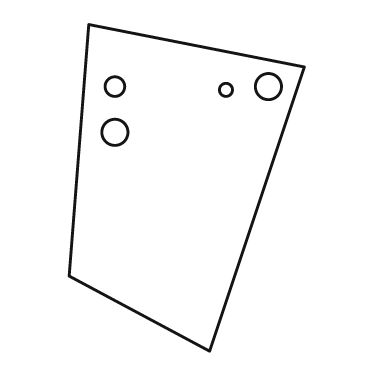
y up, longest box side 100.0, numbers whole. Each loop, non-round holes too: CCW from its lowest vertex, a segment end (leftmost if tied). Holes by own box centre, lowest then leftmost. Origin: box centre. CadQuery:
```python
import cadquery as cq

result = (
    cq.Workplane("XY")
    .moveTo(7.0, -50.0)
    .lineTo(36.0, 37.0)
    .lineTo(-30.0, 50.0)
    .lineTo(-36.0, -27.0)
    .close()
    .moveTo(-22.0, 17.0)
    .circle(4.0)
    .moveTo(12.0, 30.0)
    .circle(2.0)
    .moveTo(-22.0, 31.0)
    .circle(3.0)
    .moveTo(25.0, 31.0)
    .circle(4.0)
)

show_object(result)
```